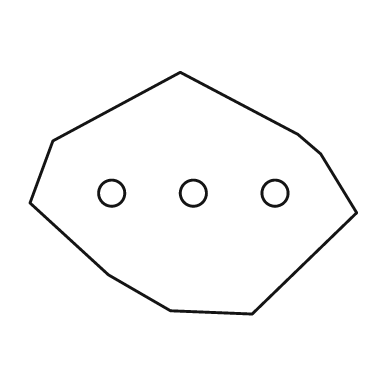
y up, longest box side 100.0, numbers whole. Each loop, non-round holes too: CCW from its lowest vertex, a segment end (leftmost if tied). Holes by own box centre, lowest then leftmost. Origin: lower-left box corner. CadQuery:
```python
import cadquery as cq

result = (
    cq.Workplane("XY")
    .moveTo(68.0, 0.0)
    .lineTo(100.0, 31.0)
    .lineTo(89.0, 49.0)
    .lineTo(82.0, 55.0)
    .lineTo(46.0, 74.0)
    .lineTo(7.0, 53.0)
    .lineTo(0.0, 34.0)
    .lineTo(24.0, 12.0)
    .lineTo(43.0, 1.0)
    .close()
    .moveTo(25.0, 37.0)
    .circle(4.0)
    .moveTo(50.0, 37.0)
    .circle(4.0)
    .moveTo(75.0, 37.0)
    .circle(4.0)
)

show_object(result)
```